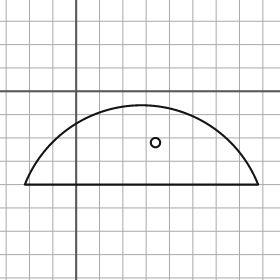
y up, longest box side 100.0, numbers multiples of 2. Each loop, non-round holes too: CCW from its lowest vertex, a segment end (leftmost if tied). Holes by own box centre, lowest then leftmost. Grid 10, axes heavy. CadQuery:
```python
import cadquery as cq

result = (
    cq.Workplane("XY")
    .moveTo(-22.0, -40.0)
    .lineTo(78.0, -40.0)
    .threePointArc((28.0, -6.0), (-22.0, -40.0))
    .close()
    .moveTo(34.0, -22.0)
    .circle(2.0)
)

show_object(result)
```